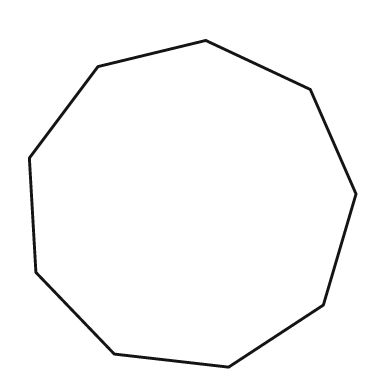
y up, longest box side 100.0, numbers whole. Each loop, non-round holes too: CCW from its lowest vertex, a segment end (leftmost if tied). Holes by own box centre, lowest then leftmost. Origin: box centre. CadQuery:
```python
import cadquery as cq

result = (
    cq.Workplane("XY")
    .moveTo(11.0, -50.0)
    .lineTo(40.0, -31.0)
    .lineTo(50.0, 3.0)
    .lineTo(36.0, 35.0)
    .lineTo(4.0, 50.0)
    .lineTo(-29.0, 42.0)
    .lineTo(-50.0, 14.0)
    .lineTo(-48.0, -21.0)
    .lineTo(-24.0, -46.0)
    .close()
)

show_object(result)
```